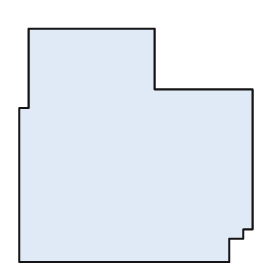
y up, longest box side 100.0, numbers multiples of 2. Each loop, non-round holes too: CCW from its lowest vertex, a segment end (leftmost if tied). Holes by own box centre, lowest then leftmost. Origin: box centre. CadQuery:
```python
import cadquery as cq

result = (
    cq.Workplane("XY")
    .moveTo(-50.0, -50.0)
    .lineTo(40.0, -50.0)
    .lineTo(40.0, -40.0)
    .lineTo(46.0, -40.0)
    .lineTo(46.0, -36.0)
    .lineTo(50.0, -36.0)
    .lineTo(50.0, 24.0)
    .lineTo(8.0, 24.0)
    .lineTo(8.0, 50.0)
    .lineTo(-46.0, 50.0)
    .lineTo(-46.0, 16.0)
    .lineTo(-50.0, 16.0)
    .close()
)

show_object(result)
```